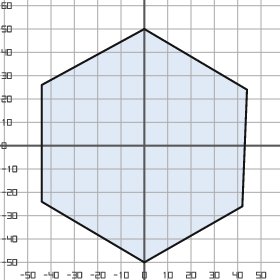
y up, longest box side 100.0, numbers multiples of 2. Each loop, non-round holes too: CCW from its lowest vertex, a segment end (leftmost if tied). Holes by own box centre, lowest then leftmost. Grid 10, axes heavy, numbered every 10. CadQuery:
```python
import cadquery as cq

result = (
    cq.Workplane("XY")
    .moveTo(0.0, -50.0)
    .lineTo(42.0, -26.0)
    .lineTo(44.0, 24.0)
    .lineTo(0.0, 50.0)
    .lineTo(-44.0, 26.0)
    .lineTo(-44.0, -24.0)
    .close()
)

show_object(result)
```